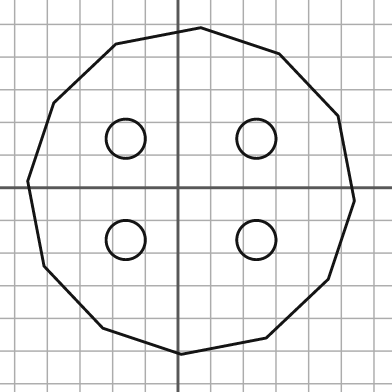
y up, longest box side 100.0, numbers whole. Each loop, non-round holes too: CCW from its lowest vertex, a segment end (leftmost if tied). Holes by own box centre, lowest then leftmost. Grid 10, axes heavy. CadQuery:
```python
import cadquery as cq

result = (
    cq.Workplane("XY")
    .moveTo(1.0, -51.0)
    .lineTo(27.0, -46.0)
    .lineTo(46.0, -28.0)
    .lineTo(54.0, -4.0)
    .lineTo(49.0, 22.0)
    .lineTo(31.0, 41.0)
    .lineTo(7.0, 49.0)
    .lineTo(-19.0, 44.0)
    .lineTo(-38.0, 26.0)
    .lineTo(-46.0, 2.0)
    .lineTo(-41.0, -24.0)
    .lineTo(-23.0, -43.0)
    .close()
    .moveTo(-16.0, -16.0)
    .circle(6.0)
    .moveTo(24.0, -16.0)
    .circle(6.0)
    .moveTo(-16.0, 15.0)
    .circle(6.0)
    .moveTo(24.0, 15.0)
    .circle(6.0)
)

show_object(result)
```